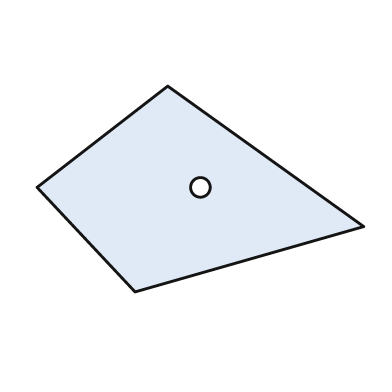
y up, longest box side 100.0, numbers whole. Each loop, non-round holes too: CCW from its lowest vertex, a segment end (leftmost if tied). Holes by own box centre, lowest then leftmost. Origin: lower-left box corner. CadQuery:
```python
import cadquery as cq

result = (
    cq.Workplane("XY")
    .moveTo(30.0, 0.0)
    .lineTo(100.0, 20.0)
    .lineTo(40.0, 63.0)
    .lineTo(0.0, 32.0)
    .close()
    .moveTo(50.0, 32.0)
    .circle(3.0)
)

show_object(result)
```